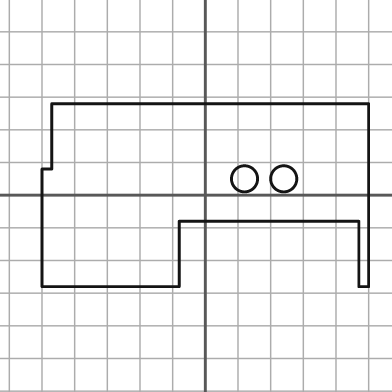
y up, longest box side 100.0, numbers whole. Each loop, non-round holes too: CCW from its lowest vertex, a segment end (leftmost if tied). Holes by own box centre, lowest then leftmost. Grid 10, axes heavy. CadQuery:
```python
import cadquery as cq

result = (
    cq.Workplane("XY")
    .moveTo(-50.0, -28.0)
    .lineTo(-8.0, -28.0)
    .lineTo(-8.0, -8.0)
    .lineTo(47.0, -8.0)
    .lineTo(47.0, -28.0)
    .lineTo(50.0, -28.0)
    .lineTo(50.0, 28.0)
    .lineTo(-47.0, 28.0)
    .lineTo(-47.0, 8.0)
    .lineTo(-50.0, 8.0)
    .close()
    .moveTo(12.0, 5.0)
    .circle(4.0)
    .moveTo(24.0, 5.0)
    .circle(4.0)
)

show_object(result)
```